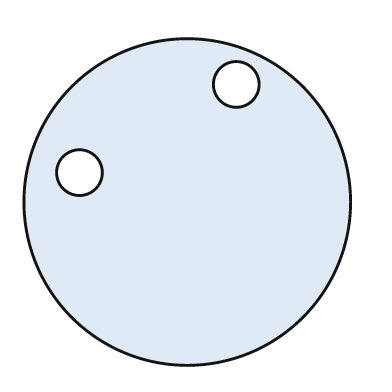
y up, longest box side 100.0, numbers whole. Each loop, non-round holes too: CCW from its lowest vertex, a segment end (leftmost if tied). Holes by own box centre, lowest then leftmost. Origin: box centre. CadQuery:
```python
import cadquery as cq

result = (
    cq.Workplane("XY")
    .moveTo(0.0, 0.0)
    .circle(50.0)
    .moveTo(-33.0, 9.0)
    .circle(7.0)
    .moveTo(15.0, 36.0)
    .circle(7.0)
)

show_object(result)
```